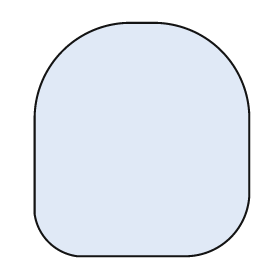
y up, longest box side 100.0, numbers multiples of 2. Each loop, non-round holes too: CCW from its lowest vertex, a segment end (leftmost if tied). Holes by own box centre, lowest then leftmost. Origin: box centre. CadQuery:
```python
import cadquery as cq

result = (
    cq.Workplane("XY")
    .moveTo(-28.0, -50.0)
    .lineTo(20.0, -50.0)
    .threePointArc((38.0, -42.0), (46.0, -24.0))
    .lineTo(46.0, 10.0)
    .threePointArc((34.0, 38.0), (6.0, 50.0))
    .lineTo(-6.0, 50.0)
    .threePointArc((-34.0, 38.0), (-46.0, 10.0))
    .lineTo(-46.0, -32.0)
    .threePointArc((-40.0, -44.0), (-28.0, -50.0))
    .close()
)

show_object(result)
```